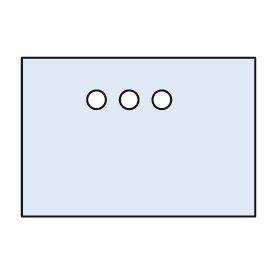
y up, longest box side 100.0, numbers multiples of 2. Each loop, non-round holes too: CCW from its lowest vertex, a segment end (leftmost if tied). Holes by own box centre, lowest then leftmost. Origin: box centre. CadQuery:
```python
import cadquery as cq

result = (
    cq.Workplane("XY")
    .moveTo(-50.0, -34.0)
    .lineTo(50.0, -34.0)
    .lineTo(50.0, 34.0)
    .lineTo(-50.0, 34.0)
    .close()
    .moveTo(-18.0, 16.0)
    .circle(4.0)
    .moveTo(-4.0, 16.0)
    .circle(4.0)
    .moveTo(10.0, 16.0)
    .circle(4.0)
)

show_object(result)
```